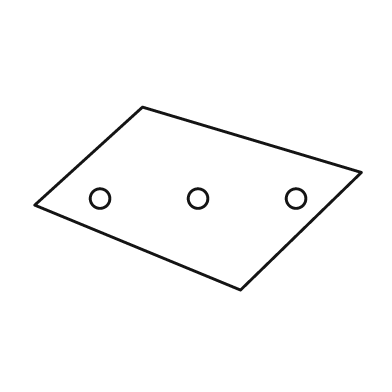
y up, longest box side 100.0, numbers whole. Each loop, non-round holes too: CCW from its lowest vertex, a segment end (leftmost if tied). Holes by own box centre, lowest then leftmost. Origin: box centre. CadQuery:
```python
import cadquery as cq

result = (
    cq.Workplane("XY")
    .moveTo(13.0, -28.0)
    .lineTo(50.0, 8.0)
    .lineTo(-17.0, 28.0)
    .lineTo(-50.0, -2.0)
    .close()
    .moveTo(-30.0, 0.0)
    .circle(3.0)
    .moveTo(0.0, 0.0)
    .circle(3.0)
    .moveTo(30.0, 0.0)
    .circle(3.0)
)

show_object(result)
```